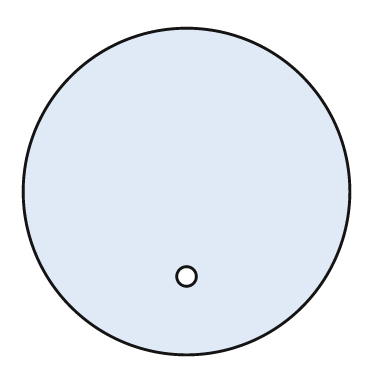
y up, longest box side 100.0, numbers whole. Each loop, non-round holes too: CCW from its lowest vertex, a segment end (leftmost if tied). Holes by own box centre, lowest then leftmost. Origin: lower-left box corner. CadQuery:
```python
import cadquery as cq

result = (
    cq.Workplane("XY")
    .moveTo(50.0, 50.0)
    .circle(50.0)
    .moveTo(50.0, 24.0)
    .circle(3.0)
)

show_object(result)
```